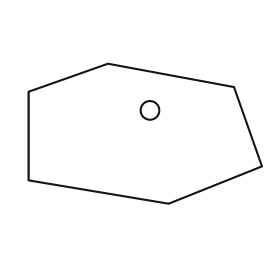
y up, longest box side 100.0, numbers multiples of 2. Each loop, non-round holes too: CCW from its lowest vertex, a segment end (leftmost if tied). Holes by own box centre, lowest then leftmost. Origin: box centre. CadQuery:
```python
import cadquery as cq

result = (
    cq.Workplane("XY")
    .moveTo(10.0, -30.0)
    .lineTo(50.0, -14.0)
    .lineTo(38.0, 20.0)
    .lineTo(-16.0, 30.0)
    .lineTo(-50.0, 18.0)
    .lineTo(-50.0, -20.0)
    .close()
    .moveTo(2.0, 10.0)
    .circle(4.0)
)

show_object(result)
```